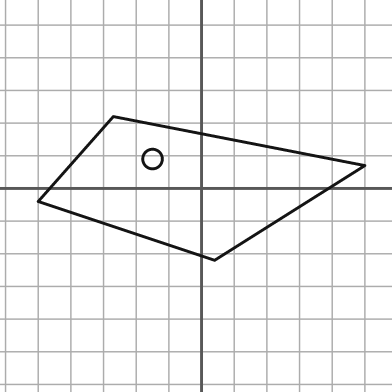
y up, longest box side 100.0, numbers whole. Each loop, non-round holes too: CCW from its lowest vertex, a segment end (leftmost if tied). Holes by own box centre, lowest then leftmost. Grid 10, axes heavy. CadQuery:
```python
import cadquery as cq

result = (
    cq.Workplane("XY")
    .moveTo(4.0, -22.0)
    .lineTo(50.0, 7.0)
    .lineTo(-27.0, 22.0)
    .lineTo(-50.0, -4.0)
    .close()
    .moveTo(-15.0, 9.0)
    .circle(3.0)
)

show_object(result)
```